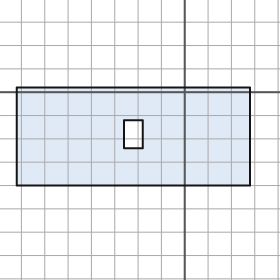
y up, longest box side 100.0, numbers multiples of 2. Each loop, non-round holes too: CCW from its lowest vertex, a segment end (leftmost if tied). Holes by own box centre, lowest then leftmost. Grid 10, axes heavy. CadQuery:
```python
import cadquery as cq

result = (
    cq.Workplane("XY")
    .moveTo(-72.0, -40.0)
    .lineTo(28.0, -40.0)
    .lineTo(28.0, 2.0)
    .lineTo(-72.0, 2.0)
    .close()
    .moveTo(-26.0, -24.0)
    .lineTo(-18.0, -24.0)
    .lineTo(-18.0, -12.0)
    .lineTo(-26.0, -12.0)
    .close()
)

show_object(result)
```